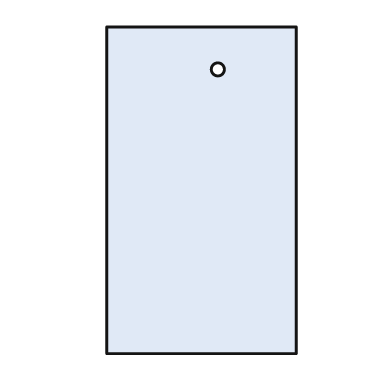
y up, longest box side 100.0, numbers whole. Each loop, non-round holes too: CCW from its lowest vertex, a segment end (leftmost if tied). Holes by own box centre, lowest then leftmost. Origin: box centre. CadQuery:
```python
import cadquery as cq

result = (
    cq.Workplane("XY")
    .moveTo(-29.0, -50.0)
    .lineTo(29.0, -50.0)
    .lineTo(29.0, 50.0)
    .lineTo(-29.0, 50.0)
    .close()
    .moveTo(5.0, 37.0)
    .circle(2.0)
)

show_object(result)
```